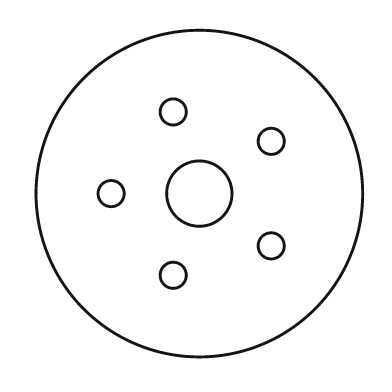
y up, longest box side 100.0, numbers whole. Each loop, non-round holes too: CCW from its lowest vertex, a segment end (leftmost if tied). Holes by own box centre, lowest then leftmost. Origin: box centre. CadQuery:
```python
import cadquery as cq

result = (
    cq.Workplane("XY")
    .moveTo(0.0, 0.0)
    .circle(50.0)
    .moveTo(-8.0, -25.0)
    .circle(4.0)
    .moveTo(22.0, -16.0)
    .circle(4.0)
    .moveTo(-27.0, 0.0)
    .circle(4.0)
    .moveTo(0.0, 0.0)
    .circle(10.0)
    .moveTo(22.0, 16.0)
    .circle(4.0)
    .moveTo(-8.0, 25.0)
    .circle(4.0)
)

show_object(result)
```